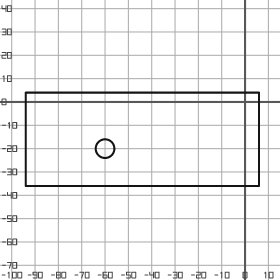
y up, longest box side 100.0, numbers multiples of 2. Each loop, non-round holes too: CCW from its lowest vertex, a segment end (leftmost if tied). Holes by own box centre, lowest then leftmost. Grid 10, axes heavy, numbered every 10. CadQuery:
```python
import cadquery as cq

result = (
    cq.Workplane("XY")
    .moveTo(-94.0, -36.0)
    .lineTo(6.0, -36.0)
    .lineTo(6.0, 4.0)
    .lineTo(-94.0, 4.0)
    .close()
    .moveTo(-60.0, -20.0)
    .circle(4.0)
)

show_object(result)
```